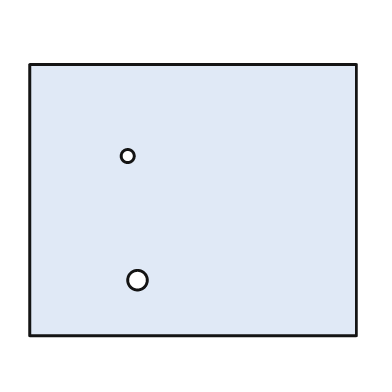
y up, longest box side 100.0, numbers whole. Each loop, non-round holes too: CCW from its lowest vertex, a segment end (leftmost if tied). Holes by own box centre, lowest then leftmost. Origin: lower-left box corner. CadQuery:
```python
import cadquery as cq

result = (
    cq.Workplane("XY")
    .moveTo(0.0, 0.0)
    .lineTo(100.0, 0.0)
    .lineTo(100.0, 83.0)
    .lineTo(0.0, 83.0)
    .close()
    .moveTo(33.0, 17.0)
    .circle(3.0)
    .moveTo(30.0, 55.0)
    .circle(2.0)
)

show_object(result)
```